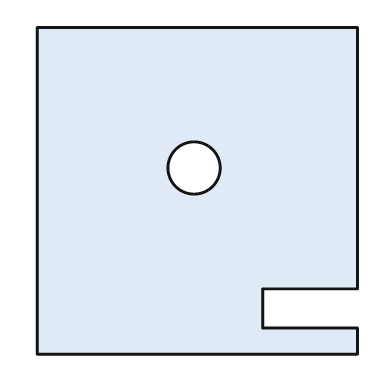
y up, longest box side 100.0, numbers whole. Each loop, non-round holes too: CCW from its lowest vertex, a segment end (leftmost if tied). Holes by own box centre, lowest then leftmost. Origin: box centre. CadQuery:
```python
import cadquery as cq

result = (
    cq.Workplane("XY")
    .moveTo(-49.0, -50.0)
    .lineTo(49.0, -50.0)
    .lineTo(49.0, -42.0)
    .lineTo(20.0, -42.0)
    .lineTo(20.0, -30.0)
    .lineTo(49.0, -30.0)
    .lineTo(49.0, 50.0)
    .lineTo(-49.0, 50.0)
    .close()
    .moveTo(-1.0, 7.0)
    .circle(8.0)
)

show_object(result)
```